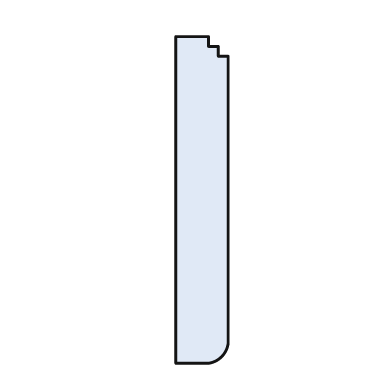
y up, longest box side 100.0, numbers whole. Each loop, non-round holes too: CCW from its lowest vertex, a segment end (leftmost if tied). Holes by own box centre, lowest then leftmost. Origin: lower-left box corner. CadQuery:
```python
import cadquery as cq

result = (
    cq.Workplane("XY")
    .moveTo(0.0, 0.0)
    .lineTo(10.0, 0.0)
    .threePointArc((14.0, 2.0), (16.0, 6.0))
    .lineTo(16.0, 94.0)
    .lineTo(13.0, 94.0)
    .lineTo(13.0, 97.0)
    .lineTo(10.0, 97.0)
    .lineTo(10.0, 100.0)
    .lineTo(0.0, 100.0)
    .close()
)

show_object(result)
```